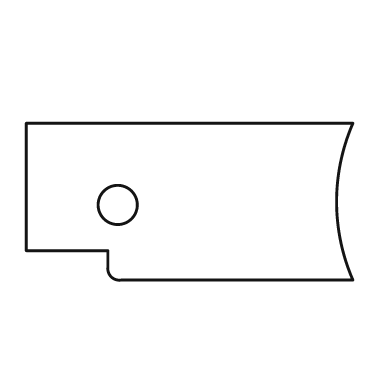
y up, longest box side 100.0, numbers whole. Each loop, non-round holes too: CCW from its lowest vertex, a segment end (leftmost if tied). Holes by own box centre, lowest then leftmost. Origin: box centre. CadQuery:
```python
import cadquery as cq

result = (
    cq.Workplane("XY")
    .moveTo(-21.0, -24.0)
    .lineTo(50.0, -24.0)
    .threePointArc((45.0, 0.0), (50.0, 24.0))
    .lineTo(-50.0, 24.0)
    .lineTo(-50.0, -15.0)
    .lineTo(-25.0, -15.0)
    .lineTo(-25.0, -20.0)
    .threePointArc((-24.0, -23.0), (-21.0, -24.0))
    .close()
    .moveTo(-22.0, -1.0)
    .circle(6.0)
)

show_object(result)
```